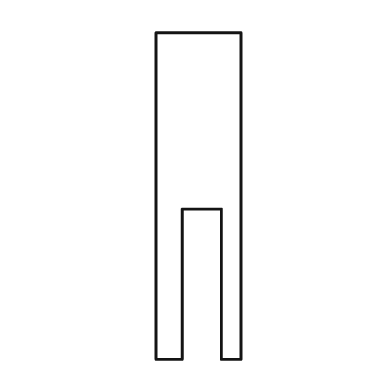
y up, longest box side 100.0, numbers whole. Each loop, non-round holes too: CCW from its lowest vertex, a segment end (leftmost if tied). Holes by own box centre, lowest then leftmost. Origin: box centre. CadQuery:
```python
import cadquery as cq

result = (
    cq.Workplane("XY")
    .moveTo(-13.0, -50.0)
    .lineTo(-5.0, -50.0)
    .lineTo(-5.0, -4.0)
    .lineTo(7.0, -4.0)
    .lineTo(7.0, -50.0)
    .lineTo(13.0, -50.0)
    .lineTo(13.0, 50.0)
    .lineTo(-13.0, 50.0)
    .close()
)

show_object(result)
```